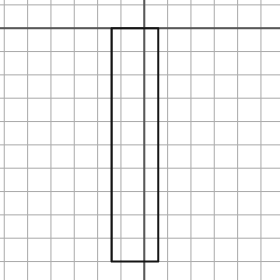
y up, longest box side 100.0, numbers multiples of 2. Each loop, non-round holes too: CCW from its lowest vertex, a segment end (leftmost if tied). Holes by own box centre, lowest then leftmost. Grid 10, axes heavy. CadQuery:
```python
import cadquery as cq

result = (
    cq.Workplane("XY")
    .moveTo(-14.0, -100.0)
    .lineTo(6.0, -100.0)
    .lineTo(6.0, 0.0)
    .lineTo(-14.0, 0.0)
    .close()
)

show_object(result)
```